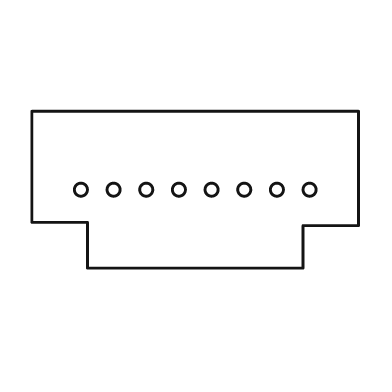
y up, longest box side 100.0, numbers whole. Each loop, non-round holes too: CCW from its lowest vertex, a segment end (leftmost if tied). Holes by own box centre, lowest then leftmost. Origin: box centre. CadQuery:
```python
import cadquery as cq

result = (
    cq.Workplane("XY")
    .moveTo(-33.0, -24.0)
    .lineTo(33.0, -24.0)
    .lineTo(33.0, -11.0)
    .lineTo(50.0, -11.0)
    .lineTo(50.0, 24.0)
    .lineTo(-50.0, 24.0)
    .lineTo(-50.0, -10.0)
    .lineTo(-33.0, -10.0)
    .close()
    .moveTo(-35.0, 0.0)
    .circle(2.0)
    .moveTo(-25.0, 0.0)
    .circle(2.0)
    .moveTo(-15.0, 0.0)
    .circle(2.0)
    .moveTo(-5.0, 0.0)
    .circle(2.0)
    .moveTo(5.0, 0.0)
    .circle(2.0)
    .moveTo(15.0, 0.0)
    .circle(2.0)
    .moveTo(25.0, 0.0)
    .circle(2.0)
    .moveTo(35.0, 0.0)
    .circle(2.0)
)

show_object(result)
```